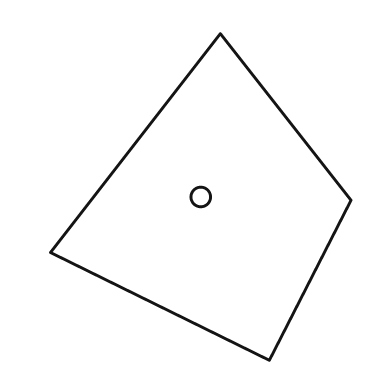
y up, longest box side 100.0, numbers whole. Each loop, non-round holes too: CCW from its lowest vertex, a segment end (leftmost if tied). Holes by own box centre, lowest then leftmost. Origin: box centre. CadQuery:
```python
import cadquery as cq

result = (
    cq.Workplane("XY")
    .moveTo(21.0, -50.0)
    .lineTo(46.0, -1.0)
    .lineTo(6.0, 50.0)
    .lineTo(-46.0, -17.0)
    .close()
    .moveTo(0.0, 0.0)
    .circle(3.0)
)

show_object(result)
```